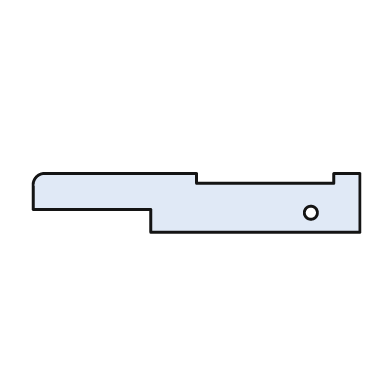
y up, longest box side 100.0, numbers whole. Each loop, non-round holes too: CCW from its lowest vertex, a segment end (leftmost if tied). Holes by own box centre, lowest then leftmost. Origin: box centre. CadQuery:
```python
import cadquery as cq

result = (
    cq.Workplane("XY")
    .moveTo(-14.0, -9.0)
    .lineTo(50.0, -9.0)
    .lineTo(50.0, 9.0)
    .lineTo(42.0, 9.0)
    .lineTo(42.0, 6.0)
    .lineTo(0.0, 6.0)
    .lineTo(0.0, 9.0)
    .lineTo(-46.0, 9.0)
    .threePointArc((-49.0, 8.0), (-50.0, 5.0))
    .lineTo(-50.0, -2.0)
    .lineTo(-14.0, -2.0)
    .close()
    .moveTo(35.0, -3.0)
    .circle(2.0)
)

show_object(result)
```